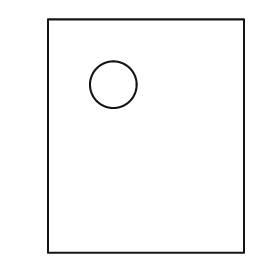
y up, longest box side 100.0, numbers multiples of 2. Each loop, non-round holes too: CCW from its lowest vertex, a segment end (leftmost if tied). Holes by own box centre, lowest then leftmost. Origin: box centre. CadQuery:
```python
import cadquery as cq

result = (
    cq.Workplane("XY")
    .moveTo(-42.0, -50.0)
    .lineTo(42.0, -50.0)
    .lineTo(42.0, 50.0)
    .lineTo(-42.0, 50.0)
    .close()
    .moveTo(-14.0, 22.0)
    .circle(10.0)
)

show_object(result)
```